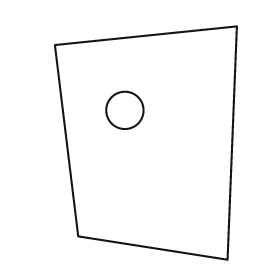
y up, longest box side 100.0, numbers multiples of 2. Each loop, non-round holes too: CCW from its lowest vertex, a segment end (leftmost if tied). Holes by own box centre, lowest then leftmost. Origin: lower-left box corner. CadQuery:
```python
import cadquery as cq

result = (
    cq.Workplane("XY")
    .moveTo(74.0, 0.0)
    .lineTo(78.0, 100.0)
    .lineTo(0.0, 92.0)
    .lineTo(10.0, 10.0)
    .close()
    .moveTo(30.0, 64.0)
    .circle(8.0)
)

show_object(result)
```